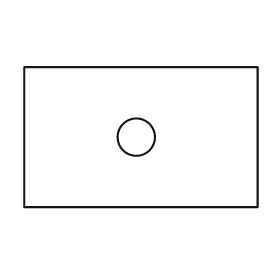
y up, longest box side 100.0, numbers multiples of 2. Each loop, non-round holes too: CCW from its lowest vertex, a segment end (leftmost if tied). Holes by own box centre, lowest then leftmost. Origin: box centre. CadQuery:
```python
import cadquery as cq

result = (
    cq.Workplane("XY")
    .moveTo(-50.0, -30.0)
    .lineTo(50.0, -30.0)
    .lineTo(50.0, 30.0)
    .lineTo(-50.0, 30.0)
    .close()
    .moveTo(-2.0, 0.0)
    .circle(8.0)
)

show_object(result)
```